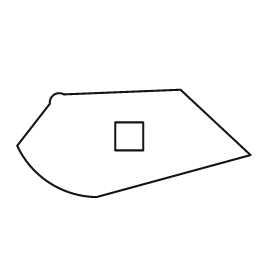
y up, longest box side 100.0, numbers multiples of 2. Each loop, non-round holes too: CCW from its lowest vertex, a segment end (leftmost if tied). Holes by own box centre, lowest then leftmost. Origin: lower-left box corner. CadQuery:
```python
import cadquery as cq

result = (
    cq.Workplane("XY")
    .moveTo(34.0, 0.0)
    .lineTo(100.0, 18.0)
    .lineTo(70.0, 46.0)
    .lineTo(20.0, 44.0)
    .threePointArc((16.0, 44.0), (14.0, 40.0))
    .lineTo(0.0, 22.0)
    .threePointArc((14.0, 6.0), (34.0, 0.0))
    .close()
    .moveTo(42.0, 20.0)
    .lineTo(54.0, 20.0)
    .lineTo(54.0, 32.0)
    .lineTo(42.0, 32.0)
    .close()
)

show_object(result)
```